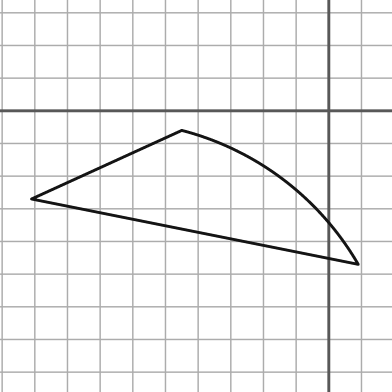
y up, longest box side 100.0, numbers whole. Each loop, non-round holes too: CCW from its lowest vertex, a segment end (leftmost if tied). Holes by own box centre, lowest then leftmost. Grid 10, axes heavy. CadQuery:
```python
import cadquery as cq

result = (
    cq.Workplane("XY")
    .moveTo(9.0, -47.0)
    .threePointArc((-14.0, -21.0), (-45.0, -6.0))
    .lineTo(-91.0, -27.0)
    .close()
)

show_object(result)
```